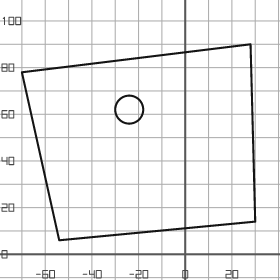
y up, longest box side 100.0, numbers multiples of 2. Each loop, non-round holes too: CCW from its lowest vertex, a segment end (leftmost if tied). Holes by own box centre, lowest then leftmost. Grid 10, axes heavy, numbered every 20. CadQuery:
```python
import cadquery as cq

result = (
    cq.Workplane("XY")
    .moveTo(-54.0, 6.0)
    .lineTo(30.0, 14.0)
    .lineTo(28.0, 90.0)
    .lineTo(-70.0, 78.0)
    .close()
    .moveTo(-24.0, 62.0)
    .circle(6.0)
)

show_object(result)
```